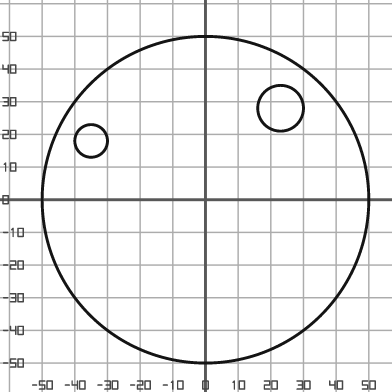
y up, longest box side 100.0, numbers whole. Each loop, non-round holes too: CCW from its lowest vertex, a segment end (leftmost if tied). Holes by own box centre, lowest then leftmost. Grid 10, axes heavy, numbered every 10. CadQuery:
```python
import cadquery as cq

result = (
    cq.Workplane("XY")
    .moveTo(0.0, 0.0)
    .circle(50.0)
    .moveTo(-35.0, 18.0)
    .circle(5.0)
    .moveTo(23.0, 28.0)
    .circle(7.0)
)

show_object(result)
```